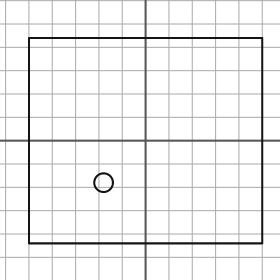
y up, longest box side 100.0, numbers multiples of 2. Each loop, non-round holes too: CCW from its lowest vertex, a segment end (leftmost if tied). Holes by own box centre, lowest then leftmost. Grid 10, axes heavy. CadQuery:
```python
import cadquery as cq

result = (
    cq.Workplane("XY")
    .moveTo(-50.0, -44.0)
    .lineTo(50.0, -44.0)
    .lineTo(50.0, 44.0)
    .lineTo(-50.0, 44.0)
    .close()
    .moveTo(-18.0, -18.0)
    .circle(4.0)
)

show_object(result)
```